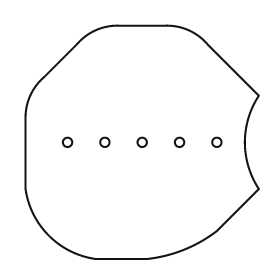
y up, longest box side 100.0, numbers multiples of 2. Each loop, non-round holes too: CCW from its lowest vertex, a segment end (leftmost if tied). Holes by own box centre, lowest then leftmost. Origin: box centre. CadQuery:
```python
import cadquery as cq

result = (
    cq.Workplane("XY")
    .moveTo(-20.0, -50.0)
    .lineTo(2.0, -50.0)
    .threePointArc((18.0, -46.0), (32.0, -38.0))
    .lineTo(50.0, -20.0)
    .threePointArc((44.0, 0.0), (50.0, 20.0))
    .lineTo(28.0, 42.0)
    .threePointArc((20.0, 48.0), (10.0, 50.0))
    .lineTo(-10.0, 50.0)
    .threePointArc((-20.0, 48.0), (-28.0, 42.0))
    .lineTo(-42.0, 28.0)
    .threePointArc((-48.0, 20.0), (-50.0, 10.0))
    .lineTo(-50.0, -20.0)
    .threePointArc((-40.0, -40.0), (-20.0, -50.0))
    .close()
    .moveTo(-32.0, 0.0)
    .circle(2.0)
    .moveTo(-16.0, 0.0)
    .circle(2.0)
    .moveTo(0.0, 0.0)
    .circle(2.0)
    .moveTo(16.0, 0.0)
    .circle(2.0)
    .moveTo(32.0, 0.0)
    .circle(2.0)
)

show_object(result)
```